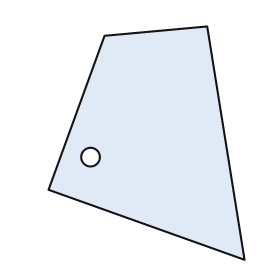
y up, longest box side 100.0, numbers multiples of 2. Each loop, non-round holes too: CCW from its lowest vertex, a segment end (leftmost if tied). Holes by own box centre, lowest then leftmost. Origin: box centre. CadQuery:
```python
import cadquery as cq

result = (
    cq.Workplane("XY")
    .moveTo(42.0, -50.0)
    .lineTo(26.0, 50.0)
    .lineTo(-18.0, 46.0)
    .lineTo(-42.0, -20.0)
    .close()
    .moveTo(-24.0, -6.0)
    .circle(4.0)
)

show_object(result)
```